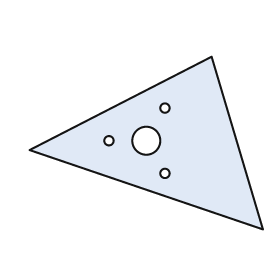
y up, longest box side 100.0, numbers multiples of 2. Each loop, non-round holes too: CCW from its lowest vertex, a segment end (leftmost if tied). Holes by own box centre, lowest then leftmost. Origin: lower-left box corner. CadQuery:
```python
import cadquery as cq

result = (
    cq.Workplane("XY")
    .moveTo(100.0, 0.0)
    .lineTo(78.0, 74.0)
    .lineTo(0.0, 34.0)
    .close()
    .moveTo(58.0, 24.0)
    .circle(2.0)
    .moveTo(34.0, 38.0)
    .circle(2.0)
    .moveTo(50.0, 38.0)
    .circle(6.0)
    .moveTo(58.0, 52.0)
    .circle(2.0)
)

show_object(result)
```